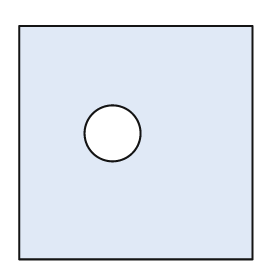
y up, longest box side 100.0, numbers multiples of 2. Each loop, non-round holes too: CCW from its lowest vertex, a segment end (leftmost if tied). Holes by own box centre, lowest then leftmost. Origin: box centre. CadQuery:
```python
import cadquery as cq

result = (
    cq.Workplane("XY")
    .moveTo(-50.0, -50.0)
    .lineTo(50.0, -50.0)
    .lineTo(50.0, 50.0)
    .lineTo(-50.0, 50.0)
    .close()
    .moveTo(-10.0, 4.0)
    .circle(12.0)
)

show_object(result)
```